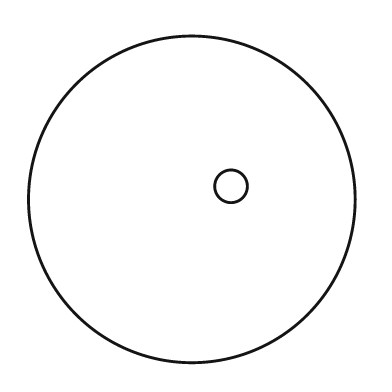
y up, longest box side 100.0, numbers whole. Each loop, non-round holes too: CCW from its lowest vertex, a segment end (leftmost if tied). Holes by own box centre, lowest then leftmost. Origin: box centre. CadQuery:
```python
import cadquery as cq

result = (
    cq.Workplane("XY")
    .moveTo(0.0, 0.0)
    .circle(50.0)
    .moveTo(12.0, 4.0)
    .circle(5.0)
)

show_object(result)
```